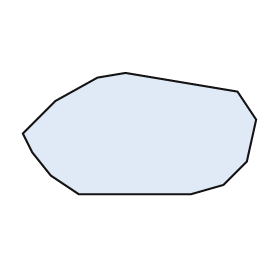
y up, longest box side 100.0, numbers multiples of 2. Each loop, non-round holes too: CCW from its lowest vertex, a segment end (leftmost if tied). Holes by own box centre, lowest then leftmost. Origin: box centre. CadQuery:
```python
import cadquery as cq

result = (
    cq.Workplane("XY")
    .moveTo(-26.0, -26.0)
    .lineTo(22.0, -26.0)
    .lineTo(36.0, -22.0)
    .lineTo(46.0, -12.0)
    .lineTo(50.0, 6.0)
    .lineTo(42.0, 18.0)
    .lineTo(-6.0, 26.0)
    .lineTo(-18.0, 24.0)
    .lineTo(-36.0, 14.0)
    .lineTo(-50.0, 0.0)
    .lineTo(-46.0, -8.0)
    .lineTo(-38.0, -18.0)
    .close()
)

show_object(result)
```